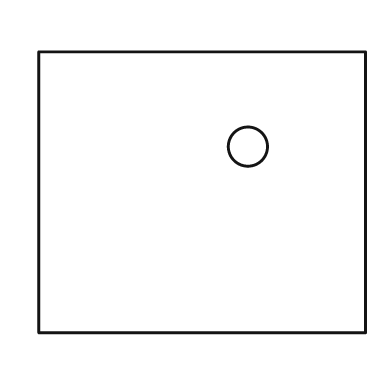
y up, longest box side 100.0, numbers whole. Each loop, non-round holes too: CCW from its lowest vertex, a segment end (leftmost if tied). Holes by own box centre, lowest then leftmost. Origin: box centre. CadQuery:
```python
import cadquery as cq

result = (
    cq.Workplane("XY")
    .moveTo(-50.0, -43.0)
    .lineTo(50.0, -43.0)
    .lineTo(50.0, 43.0)
    .lineTo(-50.0, 43.0)
    .close()
    .moveTo(14.0, 14.0)
    .circle(6.0)
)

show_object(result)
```